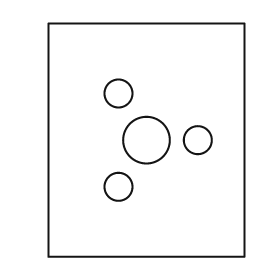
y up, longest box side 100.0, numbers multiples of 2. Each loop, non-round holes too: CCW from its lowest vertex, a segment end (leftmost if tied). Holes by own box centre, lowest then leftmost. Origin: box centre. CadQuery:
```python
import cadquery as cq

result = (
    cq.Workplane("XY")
    .moveTo(-42.0, -50.0)
    .lineTo(42.0, -50.0)
    .lineTo(42.0, 50.0)
    .lineTo(-42.0, 50.0)
    .close()
    .moveTo(-12.0, -20.0)
    .circle(6.0)
    .moveTo(0.0, 0.0)
    .circle(10.0)
    .moveTo(22.0, 0.0)
    .circle(6.0)
    .moveTo(-12.0, 20.0)
    .circle(6.0)
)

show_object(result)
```